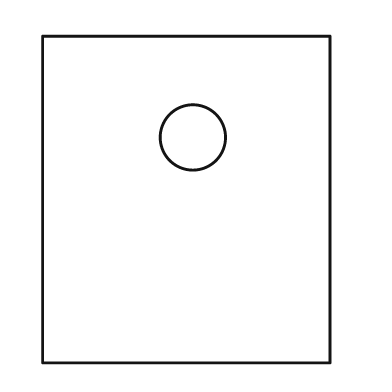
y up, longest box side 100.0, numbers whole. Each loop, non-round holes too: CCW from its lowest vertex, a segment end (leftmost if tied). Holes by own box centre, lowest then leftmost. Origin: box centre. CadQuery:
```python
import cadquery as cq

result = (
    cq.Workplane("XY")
    .moveTo(-44.0, -50.0)
    .lineTo(44.0, -50.0)
    .lineTo(44.0, 50.0)
    .lineTo(-44.0, 50.0)
    .close()
    .moveTo(2.0, 19.0)
    .circle(10.0)
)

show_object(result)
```